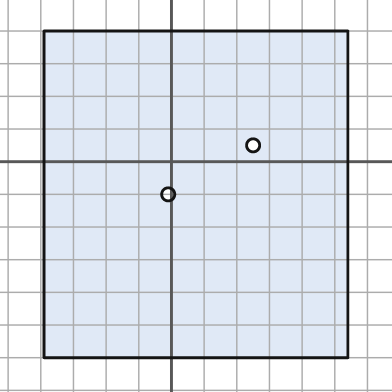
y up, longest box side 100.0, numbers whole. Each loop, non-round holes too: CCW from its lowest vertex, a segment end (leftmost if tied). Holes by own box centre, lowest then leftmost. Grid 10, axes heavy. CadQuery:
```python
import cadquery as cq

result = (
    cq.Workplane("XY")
    .moveTo(-39.0, -60.0)
    .lineTo(54.0, -60.0)
    .lineTo(54.0, 40.0)
    .lineTo(-39.0, 40.0)
    .close()
    .moveTo(-1.0, -10.0)
    .circle(2.0)
    .moveTo(25.0, 5.0)
    .circle(2.0)
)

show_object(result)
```